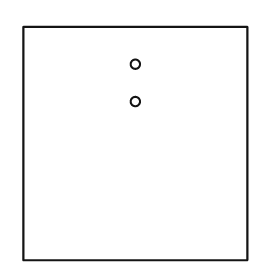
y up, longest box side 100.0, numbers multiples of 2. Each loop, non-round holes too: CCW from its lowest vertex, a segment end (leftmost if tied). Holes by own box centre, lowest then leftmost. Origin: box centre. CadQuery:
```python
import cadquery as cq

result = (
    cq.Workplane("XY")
    .moveTo(-48.0, -50.0)
    .lineTo(48.0, -50.0)
    .lineTo(48.0, 50.0)
    .lineTo(-48.0, 50.0)
    .close()
    .moveTo(0.0, 18.0)
    .circle(2.0)
    .moveTo(0.0, 34.0)
    .circle(2.0)
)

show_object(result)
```